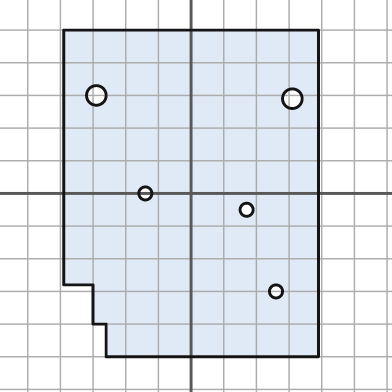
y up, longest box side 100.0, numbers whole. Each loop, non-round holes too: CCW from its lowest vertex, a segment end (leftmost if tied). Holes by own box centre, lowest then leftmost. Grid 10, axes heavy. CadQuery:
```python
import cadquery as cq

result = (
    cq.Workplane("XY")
    .moveTo(-26.0, -50.0)
    .lineTo(39.0, -50.0)
    .lineTo(39.0, 50.0)
    .lineTo(-39.0, 50.0)
    .lineTo(-39.0, -28.0)
    .lineTo(-30.0, -28.0)
    .lineTo(-30.0, -40.0)
    .lineTo(-26.0, -40.0)
    .close()
    .moveTo(26.0, -30.0)
    .circle(2.0)
    .moveTo(17.0, -5.0)
    .circle(2.0)
    .moveTo(-14.0, 0.0)
    .circle(2.0)
    .moveTo(31.0, 29.0)
    .circle(3.0)
    .moveTo(-29.0, 30.0)
    .circle(3.0)
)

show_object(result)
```